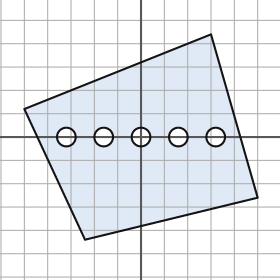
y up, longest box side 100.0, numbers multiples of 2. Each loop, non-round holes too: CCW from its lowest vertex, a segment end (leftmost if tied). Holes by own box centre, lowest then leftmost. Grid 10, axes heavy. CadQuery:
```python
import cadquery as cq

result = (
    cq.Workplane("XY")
    .moveTo(-24.0, -44.0)
    .lineTo(50.0, -26.0)
    .lineTo(30.0, 44.0)
    .lineTo(-50.0, 12.0)
    .close()
    .moveTo(-32.0, 0.0)
    .circle(4.0)
    .moveTo(-16.0, 0.0)
    .circle(4.0)
    .moveTo(0.0, 0.0)
    .circle(4.0)
    .moveTo(16.0, 0.0)
    .circle(4.0)
    .moveTo(32.0, 0.0)
    .circle(4.0)
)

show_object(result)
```